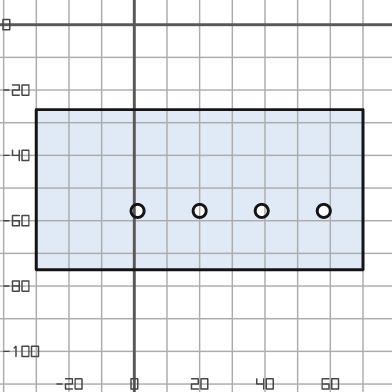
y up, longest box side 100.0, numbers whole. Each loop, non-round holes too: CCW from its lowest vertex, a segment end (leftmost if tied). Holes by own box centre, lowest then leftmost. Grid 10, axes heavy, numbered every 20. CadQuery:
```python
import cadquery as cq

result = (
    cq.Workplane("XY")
    .moveTo(-30.0, -75.0)
    .lineTo(70.0, -75.0)
    .lineTo(70.0, -26.0)
    .lineTo(-30.0, -26.0)
    .close()
    .moveTo(1.0, -57.0)
    .circle(2.0)
    .moveTo(20.0, -57.0)
    .circle(2.0)
    .moveTo(39.0, -57.0)
    .circle(2.0)
    .moveTo(58.0, -57.0)
    .circle(2.0)
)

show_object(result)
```